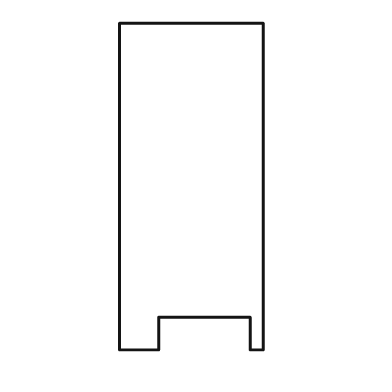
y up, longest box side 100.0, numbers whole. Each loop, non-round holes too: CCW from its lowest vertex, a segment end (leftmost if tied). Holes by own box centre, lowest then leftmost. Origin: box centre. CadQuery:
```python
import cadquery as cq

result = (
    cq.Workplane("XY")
    .moveTo(-22.0, -50.0)
    .lineTo(-10.0, -50.0)
    .lineTo(-10.0, -40.0)
    .lineTo(18.0, -40.0)
    .lineTo(18.0, -50.0)
    .lineTo(22.0, -50.0)
    .lineTo(22.0, 50.0)
    .lineTo(-22.0, 50.0)
    .close()
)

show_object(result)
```